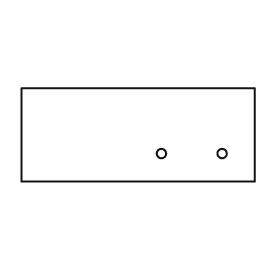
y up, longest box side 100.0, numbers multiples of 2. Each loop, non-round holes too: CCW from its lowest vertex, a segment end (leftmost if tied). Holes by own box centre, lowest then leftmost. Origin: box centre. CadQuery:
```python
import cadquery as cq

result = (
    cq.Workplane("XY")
    .moveTo(-50.0, -20.0)
    .lineTo(50.0, -20.0)
    .lineTo(50.0, 20.0)
    .lineTo(-50.0, 20.0)
    .close()
    .moveTo(10.0, -8.0)
    .circle(2.0)
    .moveTo(36.0, -8.0)
    .circle(2.0)
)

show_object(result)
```